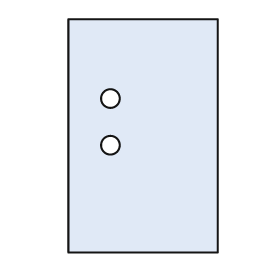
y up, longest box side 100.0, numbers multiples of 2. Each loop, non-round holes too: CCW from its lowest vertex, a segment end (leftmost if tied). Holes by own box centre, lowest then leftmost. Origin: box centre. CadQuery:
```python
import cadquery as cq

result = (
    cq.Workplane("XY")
    .moveTo(-32.0, -50.0)
    .lineTo(32.0, -50.0)
    .lineTo(32.0, 50.0)
    .lineTo(-32.0, 50.0)
    .close()
    .moveTo(-14.0, -4.0)
    .circle(4.0)
    .moveTo(-14.0, 16.0)
    .circle(4.0)
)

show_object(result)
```